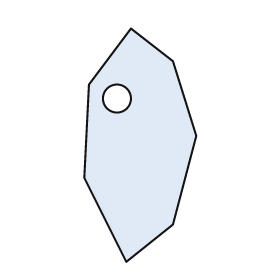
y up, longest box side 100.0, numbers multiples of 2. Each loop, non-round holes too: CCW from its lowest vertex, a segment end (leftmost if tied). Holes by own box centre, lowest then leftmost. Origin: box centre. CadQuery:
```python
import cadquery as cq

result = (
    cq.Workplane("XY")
    .moveTo(-6.0, -50.0)
    .lineTo(14.0, -34.0)
    .lineTo(24.0, 4.0)
    .lineTo(14.0, 36.0)
    .lineTo(-4.0, 50.0)
    .lineTo(-22.0, 26.0)
    .lineTo(-24.0, -14.0)
    .close()
    .moveTo(-10.0, 20.0)
    .circle(6.0)
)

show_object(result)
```